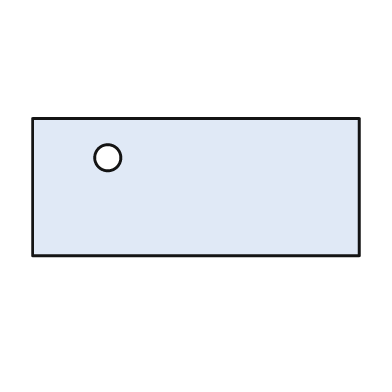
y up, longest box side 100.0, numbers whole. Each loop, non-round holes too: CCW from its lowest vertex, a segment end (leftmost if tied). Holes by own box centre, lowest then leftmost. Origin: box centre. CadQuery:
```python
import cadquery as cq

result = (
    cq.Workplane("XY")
    .moveTo(-50.0, -21.0)
    .lineTo(50.0, -21.0)
    .lineTo(50.0, 21.0)
    .lineTo(-50.0, 21.0)
    .close()
    .moveTo(-27.0, 9.0)
    .circle(4.0)
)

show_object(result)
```